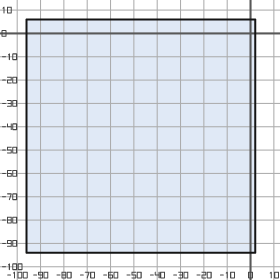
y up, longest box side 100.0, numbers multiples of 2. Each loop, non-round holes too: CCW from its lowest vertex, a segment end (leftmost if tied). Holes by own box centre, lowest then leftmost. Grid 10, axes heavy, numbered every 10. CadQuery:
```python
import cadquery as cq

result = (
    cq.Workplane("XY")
    .moveTo(-96.0, -94.0)
    .lineTo(2.0, -94.0)
    .lineTo(2.0, 6.0)
    .lineTo(-96.0, 6.0)
    .close()
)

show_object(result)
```